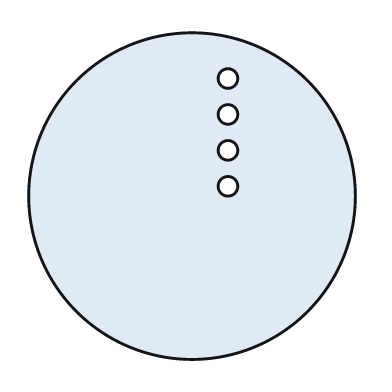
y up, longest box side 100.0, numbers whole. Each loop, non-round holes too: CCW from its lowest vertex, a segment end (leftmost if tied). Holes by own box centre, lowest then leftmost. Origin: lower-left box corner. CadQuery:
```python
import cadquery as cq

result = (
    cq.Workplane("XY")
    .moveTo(50.0, 50.0)
    .circle(50.0)
    .moveTo(61.0, 53.0)
    .circle(3.0)
    .moveTo(61.0, 64.0)
    .circle(3.0)
    .moveTo(61.0, 75.0)
    .circle(3.0)
    .moveTo(61.0, 86.0)
    .circle(3.0)
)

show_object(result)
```